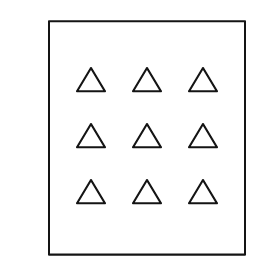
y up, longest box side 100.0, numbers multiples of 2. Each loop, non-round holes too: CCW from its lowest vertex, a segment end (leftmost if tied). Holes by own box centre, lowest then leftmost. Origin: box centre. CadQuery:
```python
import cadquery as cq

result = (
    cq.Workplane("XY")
    .moveTo(-42.0, -50.0)
    .lineTo(42.0, -50.0)
    .lineTo(42.0, 50.0)
    .lineTo(-42.0, 50.0)
    .close()
    .moveTo(-30.0, -28.0)
    .lineTo(-18.0, -28.0)
    .lineTo(-24.0, -18.0)
    .close()
    .moveTo(-6.0, -28.0)
    .lineTo(6.0, -28.0)
    .lineTo(0.0, -18.0)
    .close()
    .moveTo(18.0, -28.0)
    .lineTo(30.0, -28.0)
    .lineTo(24.0, -18.0)
    .close()
    .moveTo(-30.0, -4.0)
    .lineTo(-18.0, -4.0)
    .lineTo(-24.0, 6.0)
    .close()
    .moveTo(-6.0, -4.0)
    .lineTo(6.0, -4.0)
    .lineTo(0.0, 6.0)
    .close()
    .moveTo(18.0, -4.0)
    .lineTo(30.0, -4.0)
    .lineTo(24.0, 6.0)
    .close()
    .moveTo(-30.0, 20.0)
    .lineTo(-18.0, 20.0)
    .lineTo(-24.0, 30.0)
    .close()
    .moveTo(-6.0, 20.0)
    .lineTo(6.0, 20.0)
    .lineTo(0.0, 30.0)
    .close()
    .moveTo(18.0, 20.0)
    .lineTo(30.0, 20.0)
    .lineTo(24.0, 30.0)
    .close()
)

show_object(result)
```